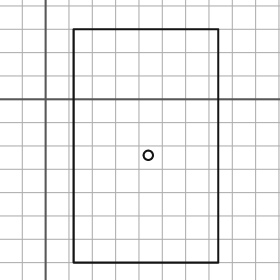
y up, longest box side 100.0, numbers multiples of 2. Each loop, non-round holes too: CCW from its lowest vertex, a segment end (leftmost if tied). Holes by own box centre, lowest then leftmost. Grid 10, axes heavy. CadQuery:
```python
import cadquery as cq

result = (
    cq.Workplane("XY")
    .moveTo(12.0, -70.0)
    .lineTo(74.0, -70.0)
    .lineTo(74.0, 30.0)
    .lineTo(12.0, 30.0)
    .close()
    .moveTo(44.0, -24.0)
    .circle(2.0)
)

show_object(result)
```